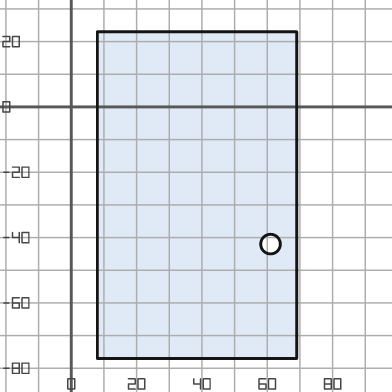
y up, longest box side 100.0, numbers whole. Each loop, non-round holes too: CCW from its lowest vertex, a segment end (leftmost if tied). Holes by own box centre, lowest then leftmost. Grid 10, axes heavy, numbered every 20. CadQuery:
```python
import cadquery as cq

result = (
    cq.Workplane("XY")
    .moveTo(8.0, -77.0)
    .lineTo(69.0, -77.0)
    .lineTo(69.0, 23.0)
    .lineTo(8.0, 23.0)
    .close()
    .moveTo(61.0, -42.0)
    .circle(3.0)
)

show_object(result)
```